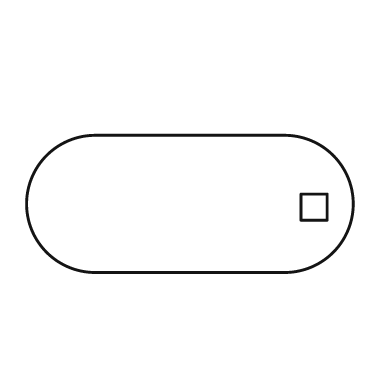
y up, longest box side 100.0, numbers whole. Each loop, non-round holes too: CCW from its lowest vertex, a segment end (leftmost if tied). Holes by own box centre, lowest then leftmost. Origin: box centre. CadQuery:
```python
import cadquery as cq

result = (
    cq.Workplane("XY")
    .moveTo(-29.0, -21.0)
    .lineTo(29.0, -21.0)
    .threePointArc((50.0, 0.0), (29.0, 21.0))
    .lineTo(-29.0, 21.0)
    .threePointArc((-50.0, 0.0), (-29.0, -21.0))
    .close()
    .moveTo(34.0, -5.0)
    .lineTo(42.0, -5.0)
    .lineTo(42.0, 3.0)
    .lineTo(34.0, 3.0)
    .close()
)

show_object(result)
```